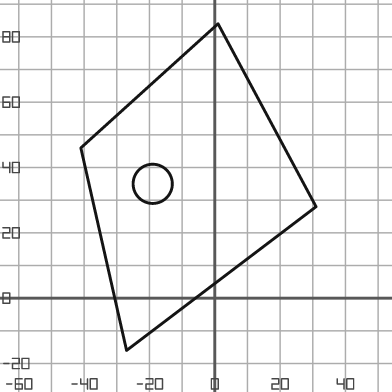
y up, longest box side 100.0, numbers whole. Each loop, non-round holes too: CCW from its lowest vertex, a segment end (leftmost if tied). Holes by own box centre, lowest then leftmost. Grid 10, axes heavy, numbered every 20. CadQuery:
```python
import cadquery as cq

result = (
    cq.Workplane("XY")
    .moveTo(-27.0, -16.0)
    .lineTo(31.0, 28.0)
    .lineTo(1.0, 84.0)
    .lineTo(-41.0, 46.0)
    .close()
    .moveTo(-19.0, 35.0)
    .circle(6.0)
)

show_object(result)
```